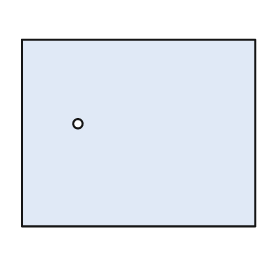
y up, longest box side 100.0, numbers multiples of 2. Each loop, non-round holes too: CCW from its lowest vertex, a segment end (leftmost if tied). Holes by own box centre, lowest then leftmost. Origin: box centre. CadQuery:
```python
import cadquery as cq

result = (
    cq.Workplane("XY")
    .moveTo(-50.0, -40.0)
    .lineTo(50.0, -40.0)
    .lineTo(50.0, 40.0)
    .lineTo(-50.0, 40.0)
    .close()
    .moveTo(-26.0, 4.0)
    .circle(2.0)
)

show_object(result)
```